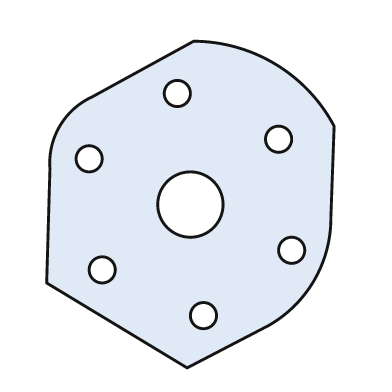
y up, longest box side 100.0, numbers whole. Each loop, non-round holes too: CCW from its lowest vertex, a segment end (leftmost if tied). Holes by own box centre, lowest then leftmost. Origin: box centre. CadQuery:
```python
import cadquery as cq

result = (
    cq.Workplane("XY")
    .moveTo(-1.0, -50.0)
    .lineTo(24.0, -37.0)
    .threePointArc((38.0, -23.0), (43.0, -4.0))
    .lineTo(44.0, 24.0)
    .threePointArc((26.0, 43.0), (1.0, 50.0))
    .lineTo(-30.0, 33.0)
    .threePointArc((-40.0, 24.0), (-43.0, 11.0))
    .lineTo(-44.0, -24.0)
    .close()
    .moveTo(4.0, -34.0)
    .circle(4.0)
    .moveTo(-27.0, -20.0)
    .circle(4.0)
    .moveTo(31.0, -14.0)
    .circle(4.0)
    .moveTo(0.0, 0.0)
    .circle(10.0)
    .moveTo(-31.0, 14.0)
    .circle(4.0)
    .moveTo(27.0, 20.0)
    .circle(4.0)
    .moveTo(-4.0, 34.0)
    .circle(4.0)
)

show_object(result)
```